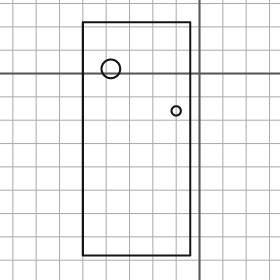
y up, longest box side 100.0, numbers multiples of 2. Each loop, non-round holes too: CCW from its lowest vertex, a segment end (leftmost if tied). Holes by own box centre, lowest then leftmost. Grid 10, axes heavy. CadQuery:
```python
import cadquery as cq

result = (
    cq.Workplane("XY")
    .moveTo(-50.0, -78.0)
    .lineTo(-4.0, -78.0)
    .lineTo(-4.0, 22.0)
    .lineTo(-50.0, 22.0)
    .close()
    .moveTo(-10.0, -16.0)
    .circle(2.0)
    .moveTo(-38.0, 2.0)
    .circle(4.0)
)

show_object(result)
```